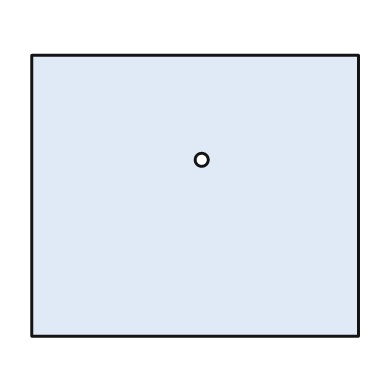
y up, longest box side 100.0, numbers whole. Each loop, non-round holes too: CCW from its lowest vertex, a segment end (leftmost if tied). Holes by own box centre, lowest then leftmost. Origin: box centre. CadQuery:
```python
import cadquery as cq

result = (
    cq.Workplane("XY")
    .moveTo(-50.0, -43.0)
    .lineTo(50.0, -43.0)
    .lineTo(50.0, 43.0)
    .lineTo(-50.0, 43.0)
    .close()
    .moveTo(2.0, 11.0)
    .circle(2.0)
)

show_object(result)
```